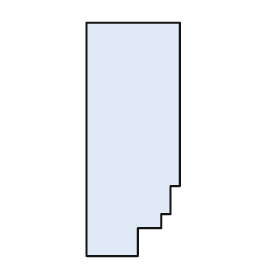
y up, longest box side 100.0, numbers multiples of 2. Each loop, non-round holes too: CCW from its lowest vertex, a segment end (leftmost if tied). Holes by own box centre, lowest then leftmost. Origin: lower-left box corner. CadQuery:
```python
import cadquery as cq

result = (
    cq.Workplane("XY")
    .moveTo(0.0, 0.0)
    .lineTo(22.0, 0.0)
    .lineTo(22.0, 12.0)
    .lineTo(32.0, 12.0)
    .lineTo(32.0, 18.0)
    .lineTo(36.0, 18.0)
    .lineTo(36.0, 30.0)
    .lineTo(40.0, 30.0)
    .lineTo(40.0, 100.0)
    .lineTo(0.0, 100.0)
    .close()
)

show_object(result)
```